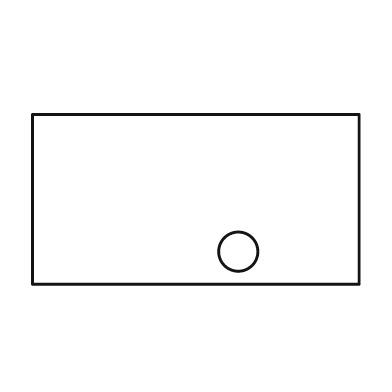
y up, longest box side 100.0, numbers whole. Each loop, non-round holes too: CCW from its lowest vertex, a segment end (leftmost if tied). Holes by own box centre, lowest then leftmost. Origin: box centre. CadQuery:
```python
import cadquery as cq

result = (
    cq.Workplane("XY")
    .moveTo(-50.0, -26.0)
    .lineTo(50.0, -26.0)
    .lineTo(50.0, 26.0)
    .lineTo(-50.0, 26.0)
    .close()
    .moveTo(13.0, -16.0)
    .circle(6.0)
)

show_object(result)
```